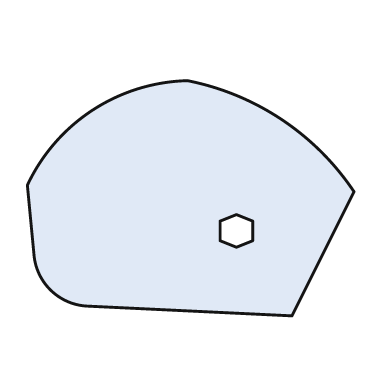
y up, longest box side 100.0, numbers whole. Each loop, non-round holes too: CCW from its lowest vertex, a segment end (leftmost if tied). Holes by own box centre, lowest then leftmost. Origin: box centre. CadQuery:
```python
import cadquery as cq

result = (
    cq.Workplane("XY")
    .moveTo(31.0, -36.0)
    .lineTo(50.0, 2.0)
    .threePointArc((28.0, 24.0), (-1.0, 36.0))
    .threePointArc((-30.0, 27.0), (-50.0, 4.0))
    .lineTo(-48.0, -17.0)
    .threePointArc((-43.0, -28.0), (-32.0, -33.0))
    .close()
    .moveTo(14.0, -15.0)
    .lineTo(19.0, -13.0)
    .lineTo(19.0, -7.0)
    .lineTo(14.0, -5.0)
    .lineTo(9.0, -7.0)
    .lineTo(9.0, -13.0)
    .close()
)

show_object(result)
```